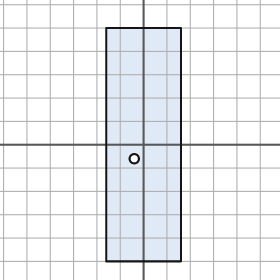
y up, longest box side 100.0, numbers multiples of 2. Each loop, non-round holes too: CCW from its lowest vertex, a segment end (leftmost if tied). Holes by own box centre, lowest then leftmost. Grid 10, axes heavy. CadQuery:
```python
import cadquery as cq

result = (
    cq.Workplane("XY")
    .moveTo(-16.0, -50.0)
    .lineTo(16.0, -50.0)
    .lineTo(16.0, 50.0)
    .lineTo(-16.0, 50.0)
    .close()
    .moveTo(-4.0, -6.0)
    .circle(2.0)
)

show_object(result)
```